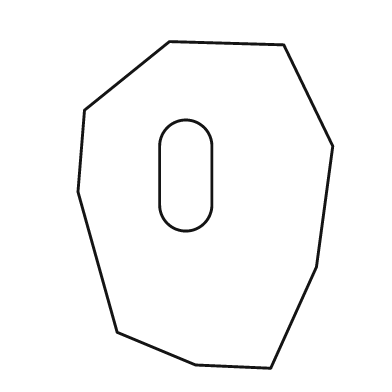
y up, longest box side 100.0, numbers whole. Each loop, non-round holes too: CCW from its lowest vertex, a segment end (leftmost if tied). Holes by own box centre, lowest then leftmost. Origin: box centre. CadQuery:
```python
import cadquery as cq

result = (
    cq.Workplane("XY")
    .moveTo(20.0, -50.0)
    .lineTo(34.0, -19.0)
    .lineTo(39.0, 18.0)
    .lineTo(24.0, 49.0)
    .lineTo(-11.0, 50.0)
    .lineTo(-37.0, 29.0)
    .lineTo(-39.0, 4.0)
    .lineTo(-27.0, -39.0)
    .lineTo(-3.0, -49.0)
    .close()
    .moveTo(-14.0, 0.0)
    .threePointArc((-6.0, -8.0), (2.0, 0.0))
    .lineTo(2.0, 18.0)
    .threePointArc((-6.0, 26.0), (-14.0, 18.0))
    .close()
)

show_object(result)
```